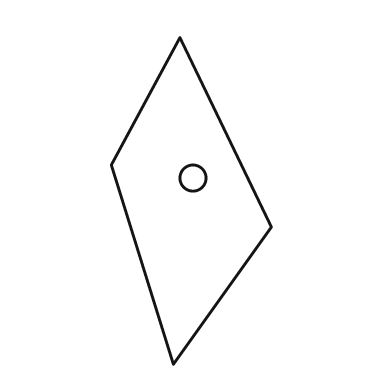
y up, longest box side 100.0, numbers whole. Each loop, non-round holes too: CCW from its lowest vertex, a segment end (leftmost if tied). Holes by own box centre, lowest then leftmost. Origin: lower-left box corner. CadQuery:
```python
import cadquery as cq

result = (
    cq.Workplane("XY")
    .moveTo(19.0, 0.0)
    .lineTo(49.0, 42.0)
    .lineTo(21.0, 100.0)
    .lineTo(0.0, 61.0)
    .close()
    .moveTo(25.0, 57.0)
    .circle(4.0)
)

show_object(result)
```